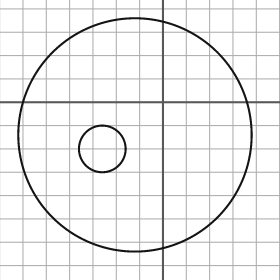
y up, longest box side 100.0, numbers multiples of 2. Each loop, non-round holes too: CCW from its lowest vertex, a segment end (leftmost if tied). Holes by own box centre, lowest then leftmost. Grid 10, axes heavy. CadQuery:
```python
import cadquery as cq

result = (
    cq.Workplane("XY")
    .moveTo(-12.0, -14.0)
    .circle(50.0)
    .moveTo(-26.0, -20.0)
    .circle(10.0)
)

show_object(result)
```